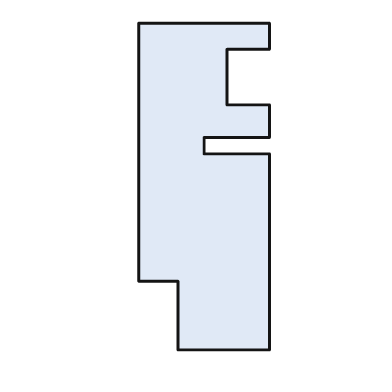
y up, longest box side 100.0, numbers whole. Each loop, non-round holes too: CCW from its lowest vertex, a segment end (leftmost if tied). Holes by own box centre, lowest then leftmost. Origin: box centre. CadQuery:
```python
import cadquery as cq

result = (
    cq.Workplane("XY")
    .moveTo(-8.0, -50.0)
    .lineTo(20.0, -50.0)
    .lineTo(20.0, 10.0)
    .lineTo(0.0, 10.0)
    .lineTo(0.0, 15.0)
    .lineTo(20.0, 15.0)
    .lineTo(20.0, 25.0)
    .lineTo(7.0, 25.0)
    .lineTo(7.0, 42.0)
    .lineTo(20.0, 42.0)
    .lineTo(20.0, 50.0)
    .lineTo(-20.0, 50.0)
    .lineTo(-20.0, -29.0)
    .lineTo(-8.0, -29.0)
    .close()
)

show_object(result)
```